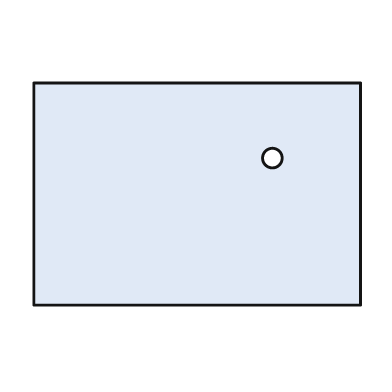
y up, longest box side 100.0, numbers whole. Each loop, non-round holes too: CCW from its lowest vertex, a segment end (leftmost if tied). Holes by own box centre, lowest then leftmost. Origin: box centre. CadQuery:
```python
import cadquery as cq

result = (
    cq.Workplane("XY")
    .moveTo(-50.0, -34.0)
    .lineTo(50.0, -34.0)
    .lineTo(50.0, 34.0)
    .lineTo(-50.0, 34.0)
    .close()
    .moveTo(23.0, 11.0)
    .circle(3.0)
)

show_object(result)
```